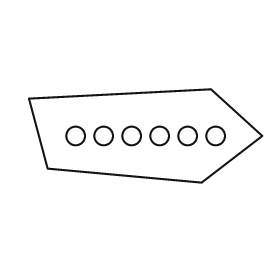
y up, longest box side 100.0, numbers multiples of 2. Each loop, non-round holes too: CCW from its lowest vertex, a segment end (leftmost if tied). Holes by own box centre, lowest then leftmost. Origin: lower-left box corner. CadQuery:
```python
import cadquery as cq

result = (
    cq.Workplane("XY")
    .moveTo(74.0, 0.0)
    .lineTo(100.0, 20.0)
    .lineTo(78.0, 40.0)
    .lineTo(0.0, 36.0)
    .lineTo(8.0, 6.0)
    .close()
    .moveTo(20.0, 20.0)
    .circle(4.0)
    .moveTo(32.0, 20.0)
    .circle(4.0)
    .moveTo(44.0, 20.0)
    .circle(4.0)
    .moveTo(56.0, 20.0)
    .circle(4.0)
    .moveTo(68.0, 20.0)
    .circle(4.0)
    .moveTo(80.0, 20.0)
    .circle(4.0)
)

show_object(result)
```